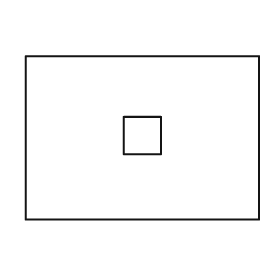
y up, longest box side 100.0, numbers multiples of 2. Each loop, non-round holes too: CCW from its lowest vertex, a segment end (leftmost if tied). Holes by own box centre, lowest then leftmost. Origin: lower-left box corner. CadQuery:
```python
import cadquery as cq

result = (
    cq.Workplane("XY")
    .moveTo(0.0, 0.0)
    .lineTo(100.0, 0.0)
    .lineTo(100.0, 70.0)
    .lineTo(0.0, 70.0)
    .close()
    .moveTo(42.0, 28.0)
    .lineTo(58.0, 28.0)
    .lineTo(58.0, 44.0)
    .lineTo(42.0, 44.0)
    .close()
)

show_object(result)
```